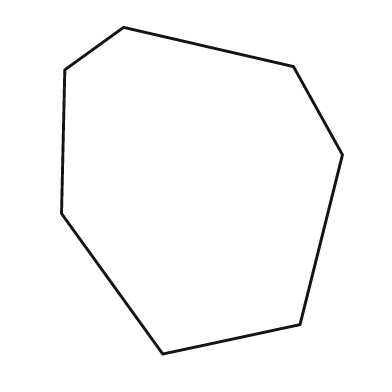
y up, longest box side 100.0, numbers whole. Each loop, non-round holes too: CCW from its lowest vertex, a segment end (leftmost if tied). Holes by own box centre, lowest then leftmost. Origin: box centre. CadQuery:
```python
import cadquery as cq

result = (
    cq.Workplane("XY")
    .moveTo(-12.0, -50.0)
    .lineTo(30.0, -41.0)
    .lineTo(43.0, 11.0)
    .lineTo(28.0, 38.0)
    .lineTo(-24.0, 50.0)
    .lineTo(-42.0, 37.0)
    .lineTo(-43.0, -7.0)
    .close()
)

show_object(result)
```